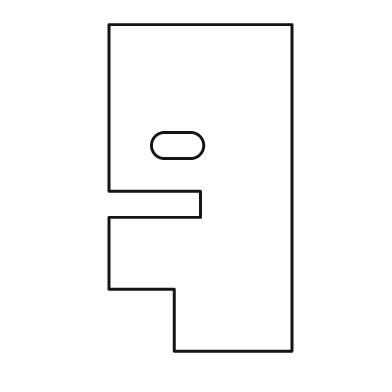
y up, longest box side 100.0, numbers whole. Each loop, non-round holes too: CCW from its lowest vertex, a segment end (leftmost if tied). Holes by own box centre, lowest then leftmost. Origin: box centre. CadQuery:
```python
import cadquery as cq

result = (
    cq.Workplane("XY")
    .moveTo(-8.0, -50.0)
    .lineTo(28.0, -50.0)
    .lineTo(28.0, 50.0)
    .lineTo(-28.0, 50.0)
    .lineTo(-28.0, -1.0)
    .lineTo(0.0, -1.0)
    .lineTo(0.0, -9.0)
    .lineTo(-28.0, -9.0)
    .lineTo(-28.0, -31.0)
    .lineTo(-8.0, -31.0)
    .close()
    .moveTo(-11.0, 9.0)
    .lineTo(-3.0, 9.0)
    .threePointArc((1.0, 13.0), (-3.0, 17.0))
    .lineTo(-11.0, 17.0)
    .threePointArc((-15.0, 13.0), (-11.0, 9.0))
    .close()
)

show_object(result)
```